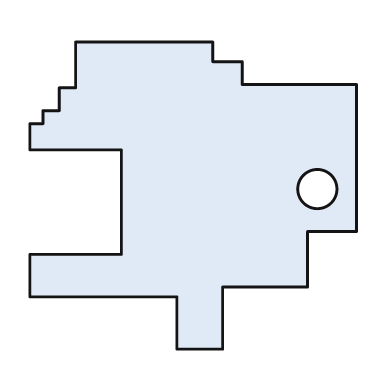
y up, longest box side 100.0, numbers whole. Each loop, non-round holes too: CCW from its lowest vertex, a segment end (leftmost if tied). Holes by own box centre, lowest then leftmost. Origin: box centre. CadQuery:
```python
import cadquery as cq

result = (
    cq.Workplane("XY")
    .moveTo(-5.0, -47.0)
    .lineTo(9.0, -47.0)
    .lineTo(9.0, -28.0)
    .lineTo(35.0, -28.0)
    .lineTo(35.0, -11.0)
    .lineTo(50.0, -11.0)
    .lineTo(50.0, 34.0)
    .lineTo(15.0, 34.0)
    .lineTo(15.0, 41.0)
    .lineTo(6.0, 41.0)
    .lineTo(6.0, 47.0)
    .lineTo(-36.0, 47.0)
    .lineTo(-36.0, 33.0)
    .lineTo(-41.0, 33.0)
    .lineTo(-41.0, 26.0)
    .lineTo(-46.0, 26.0)
    .lineTo(-46.0, 22.0)
    .lineTo(-50.0, 22.0)
    .lineTo(-50.0, 14.0)
    .lineTo(-22.0, 14.0)
    .lineTo(-22.0, -18.0)
    .lineTo(-50.0, -18.0)
    .lineTo(-50.0, -31.0)
    .lineTo(-5.0, -31.0)
    .close()
    .moveTo(38.0, 2.0)
    .circle(6.0)
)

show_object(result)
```